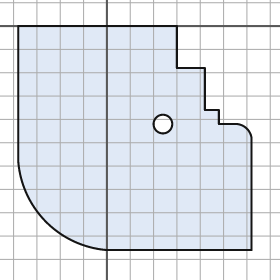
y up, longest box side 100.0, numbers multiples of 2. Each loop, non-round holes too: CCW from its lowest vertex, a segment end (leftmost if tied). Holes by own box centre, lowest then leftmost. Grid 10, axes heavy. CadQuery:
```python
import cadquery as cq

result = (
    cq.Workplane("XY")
    .moveTo(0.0, -96.0)
    .lineTo(62.0, -96.0)
    .lineTo(62.0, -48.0)
    .threePointArc((60.0, -44.0), (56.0, -42.0))
    .lineTo(48.0, -42.0)
    .lineTo(48.0, -36.0)
    .lineTo(42.0, -36.0)
    .lineTo(42.0, -18.0)
    .lineTo(30.0, -18.0)
    .lineTo(30.0, 0.0)
    .lineTo(-38.0, 0.0)
    .lineTo(-38.0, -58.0)
    .threePointArc((-26.0, -84.0), (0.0, -96.0))
    .close()
    .moveTo(24.0, -42.0)
    .circle(4.0)
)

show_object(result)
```